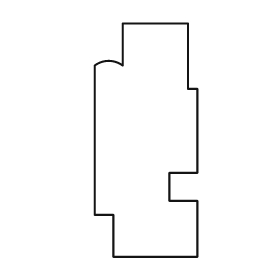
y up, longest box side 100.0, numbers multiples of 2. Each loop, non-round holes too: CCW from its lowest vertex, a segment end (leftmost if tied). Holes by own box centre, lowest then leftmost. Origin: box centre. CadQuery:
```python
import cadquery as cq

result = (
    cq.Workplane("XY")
    .moveTo(-14.0, -50.0)
    .lineTo(22.0, -50.0)
    .lineTo(22.0, -26.0)
    .lineTo(10.0, -26.0)
    .lineTo(10.0, -14.0)
    .lineTo(22.0, -14.0)
    .lineTo(22.0, 22.0)
    .lineTo(18.0, 22.0)
    .lineTo(18.0, 50.0)
    .lineTo(-10.0, 50.0)
    .lineTo(-10.0, 32.0)
    .threePointArc((-16.0, 34.0), (-22.0, 32.0))
    .lineTo(-22.0, -32.0)
    .lineTo(-14.0, -32.0)
    .close()
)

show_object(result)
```